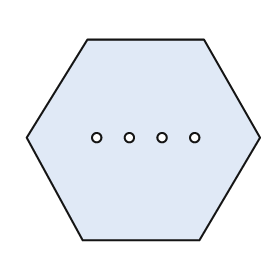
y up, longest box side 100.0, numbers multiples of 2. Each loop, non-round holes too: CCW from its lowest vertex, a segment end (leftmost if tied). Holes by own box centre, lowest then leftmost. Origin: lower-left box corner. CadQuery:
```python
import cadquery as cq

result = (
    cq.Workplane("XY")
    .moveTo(24.0, 0.0)
    .lineTo(74.0, 0.0)
    .lineTo(100.0, 44.0)
    .lineTo(76.0, 86.0)
    .lineTo(26.0, 86.0)
    .lineTo(0.0, 44.0)
    .close()
    .moveTo(30.0, 44.0)
    .circle(2.0)
    .moveTo(44.0, 44.0)
    .circle(2.0)
    .moveTo(58.0, 44.0)
    .circle(2.0)
    .moveTo(72.0, 44.0)
    .circle(2.0)
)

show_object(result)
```